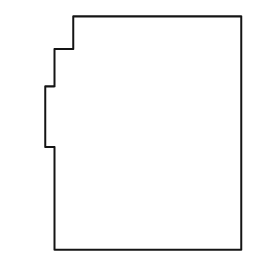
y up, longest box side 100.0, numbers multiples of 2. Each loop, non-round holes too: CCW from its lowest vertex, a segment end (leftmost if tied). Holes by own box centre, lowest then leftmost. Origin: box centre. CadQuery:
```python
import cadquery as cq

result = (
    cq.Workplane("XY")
    .moveTo(-38.0, -50.0)
    .lineTo(42.0, -50.0)
    .lineTo(42.0, 50.0)
    .lineTo(-30.0, 50.0)
    .lineTo(-30.0, 36.0)
    .lineTo(-38.0, 36.0)
    .lineTo(-38.0, 20.0)
    .lineTo(-42.0, 20.0)
    .lineTo(-42.0, -6.0)
    .lineTo(-38.0, -6.0)
    .close()
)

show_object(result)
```